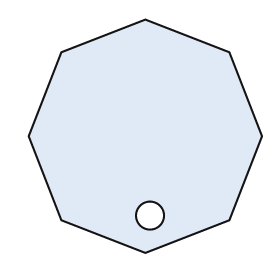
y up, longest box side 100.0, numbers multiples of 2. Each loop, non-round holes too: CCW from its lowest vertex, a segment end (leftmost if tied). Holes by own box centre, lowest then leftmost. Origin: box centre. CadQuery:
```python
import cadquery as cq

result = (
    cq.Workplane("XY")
    .moveTo(0.0, -50.0)
    .lineTo(36.0, -36.0)
    .lineTo(50.0, 0.0)
    .lineTo(36.0, 36.0)
    .lineTo(0.0, 50.0)
    .lineTo(-36.0, 36.0)
    .lineTo(-50.0, 0.0)
    .lineTo(-36.0, -36.0)
    .close()
    .moveTo(2.0, -34.0)
    .circle(6.0)
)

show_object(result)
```